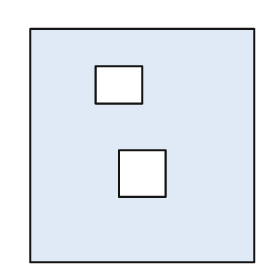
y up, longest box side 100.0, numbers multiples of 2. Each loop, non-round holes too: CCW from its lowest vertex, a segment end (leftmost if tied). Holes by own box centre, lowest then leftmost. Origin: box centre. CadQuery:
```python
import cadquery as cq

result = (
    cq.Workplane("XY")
    .moveTo(-48.0, -50.0)
    .lineTo(48.0, -50.0)
    .lineTo(48.0, 50.0)
    .lineTo(-48.0, 50.0)
    .close()
    .moveTo(-10.0, -22.0)
    .lineTo(10.0, -22.0)
    .lineTo(10.0, -2.0)
    .lineTo(-10.0, -2.0)
    .close()
    .moveTo(-20.0, 18.0)
    .lineTo(0.0, 18.0)
    .lineTo(0.0, 34.0)
    .lineTo(-20.0, 34.0)
    .close()
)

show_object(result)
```